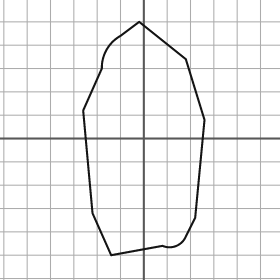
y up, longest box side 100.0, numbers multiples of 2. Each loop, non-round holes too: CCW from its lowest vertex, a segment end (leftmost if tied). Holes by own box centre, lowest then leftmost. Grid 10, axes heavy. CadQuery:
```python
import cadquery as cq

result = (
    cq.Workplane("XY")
    .moveTo(-14.0, -50.0)
    .lineTo(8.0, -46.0)
    .threePointArc((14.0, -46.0), (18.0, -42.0))
    .lineTo(22.0, -34.0)
    .lineTo(26.0, 8.0)
    .lineTo(18.0, 34.0)
    .lineTo(-2.0, 50.0)
    .lineTo(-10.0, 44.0)
    .threePointArc((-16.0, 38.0), (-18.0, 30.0))
    .lineTo(-26.0, 12.0)
    .lineTo(-22.0, -32.0)
    .close()
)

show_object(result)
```